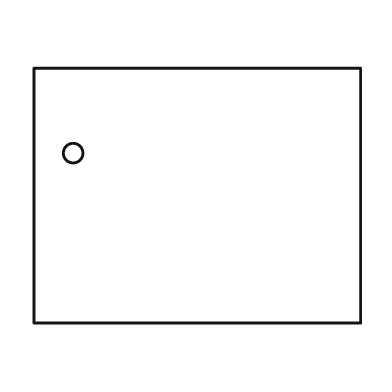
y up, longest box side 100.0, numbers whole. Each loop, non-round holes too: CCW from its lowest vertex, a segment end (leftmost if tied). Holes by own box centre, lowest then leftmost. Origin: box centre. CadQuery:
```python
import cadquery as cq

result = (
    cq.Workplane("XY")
    .moveTo(-50.0, -39.0)
    .lineTo(50.0, -39.0)
    .lineTo(50.0, 39.0)
    .lineTo(-50.0, 39.0)
    .close()
    .moveTo(-38.0, 13.0)
    .circle(3.0)
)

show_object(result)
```